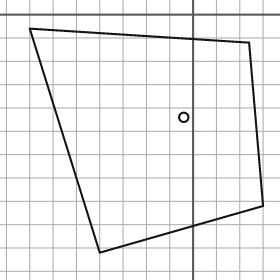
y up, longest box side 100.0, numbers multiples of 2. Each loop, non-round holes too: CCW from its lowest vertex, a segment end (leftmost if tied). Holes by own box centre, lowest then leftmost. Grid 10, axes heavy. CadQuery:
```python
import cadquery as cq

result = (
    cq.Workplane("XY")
    .moveTo(-40.0, -102.0)
    .lineTo(30.0, -82.0)
    .lineTo(24.0, -12.0)
    .lineTo(-70.0, -6.0)
    .close()
    .moveTo(-4.0, -44.0)
    .circle(2.0)
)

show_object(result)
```